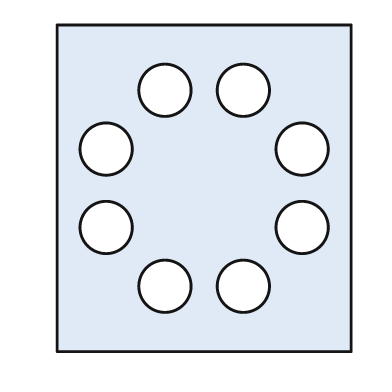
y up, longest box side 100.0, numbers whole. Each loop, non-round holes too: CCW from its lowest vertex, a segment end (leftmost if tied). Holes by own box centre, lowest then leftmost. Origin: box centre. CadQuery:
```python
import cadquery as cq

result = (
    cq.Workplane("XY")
    .moveTo(-45.0, -50.0)
    .lineTo(45.0, -50.0)
    .lineTo(45.0, 50.0)
    .lineTo(-45.0, 50.0)
    .close()
    .moveTo(-12.0, -30.0)
    .circle(8.0)
    .moveTo(12.0, -30.0)
    .circle(8.0)
    .moveTo(-30.0, -12.0)
    .circle(8.0)
    .moveTo(30.0, -12.0)
    .circle(8.0)
    .moveTo(-30.0, 12.0)
    .circle(8.0)
    .moveTo(30.0, 12.0)
    .circle(8.0)
    .moveTo(-12.0, 30.0)
    .circle(8.0)
    .moveTo(12.0, 30.0)
    .circle(8.0)
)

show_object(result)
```